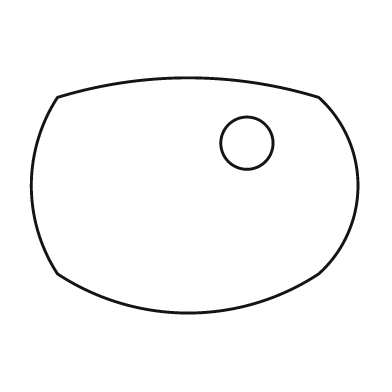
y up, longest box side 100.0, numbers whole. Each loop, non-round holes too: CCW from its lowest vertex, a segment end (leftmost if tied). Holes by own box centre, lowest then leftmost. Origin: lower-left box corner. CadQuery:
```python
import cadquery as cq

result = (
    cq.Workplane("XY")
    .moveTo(8.0, 12.0)
    .threePointArc((48.0, 0.0), (88.0, 12.0))
    .threePointArc((100.0, 39.0), (88.0, 66.0))
    .threePointArc((48.0, 72.0), (8.0, 66.0))
    .threePointArc((0.0, 39.0), (8.0, 12.0))
    .close()
    .moveTo(66.0, 52.0)
    .circle(8.0)
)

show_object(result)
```